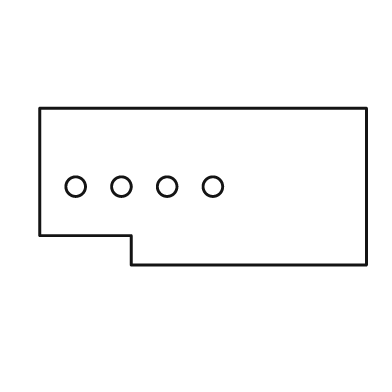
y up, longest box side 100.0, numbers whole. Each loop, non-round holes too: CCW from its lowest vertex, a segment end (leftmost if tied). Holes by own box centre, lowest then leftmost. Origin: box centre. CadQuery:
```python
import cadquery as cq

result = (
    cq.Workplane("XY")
    .moveTo(-22.0, -24.0)
    .lineTo(50.0, -24.0)
    .lineTo(50.0, 24.0)
    .lineTo(-50.0, 24.0)
    .lineTo(-50.0, -15.0)
    .lineTo(-22.0, -15.0)
    .close()
    .moveTo(-39.0, 0.0)
    .circle(3.0)
    .moveTo(-25.0, 0.0)
    .circle(3.0)
    .moveTo(-11.0, 0.0)
    .circle(3.0)
    .moveTo(3.0, 0.0)
    .circle(3.0)
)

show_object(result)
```